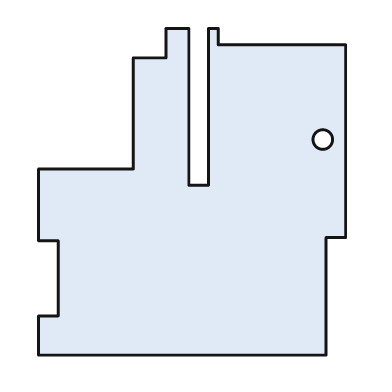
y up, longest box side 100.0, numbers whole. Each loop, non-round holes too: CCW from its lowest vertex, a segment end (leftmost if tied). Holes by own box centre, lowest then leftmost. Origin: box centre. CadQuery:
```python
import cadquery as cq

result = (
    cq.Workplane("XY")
    .moveTo(-47.0, -50.0)
    .lineTo(41.0, -50.0)
    .lineTo(41.0, -14.0)
    .lineTo(47.0, -14.0)
    .lineTo(47.0, 45.0)
    .lineTo(8.0, 45.0)
    .lineTo(8.0, 50.0)
    .lineTo(5.0, 50.0)
    .lineTo(5.0, 2.0)
    .lineTo(-1.0, 2.0)
    .lineTo(-1.0, 50.0)
    .lineTo(-8.0, 50.0)
    .lineTo(-8.0, 41.0)
    .lineTo(-18.0, 41.0)
    .lineTo(-18.0, 7.0)
    .lineTo(-47.0, 7.0)
    .lineTo(-47.0, -15.0)
    .lineTo(-41.0, -15.0)
    .lineTo(-41.0, -38.0)
    .lineTo(-47.0, -38.0)
    .close()
    .moveTo(40.0, 16.0)
    .circle(3.0)
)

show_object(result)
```